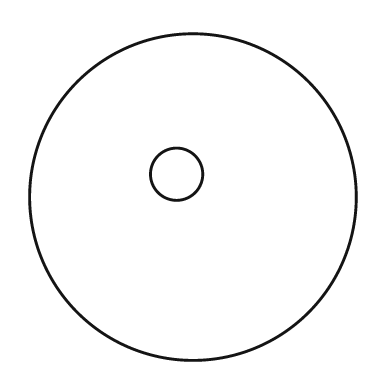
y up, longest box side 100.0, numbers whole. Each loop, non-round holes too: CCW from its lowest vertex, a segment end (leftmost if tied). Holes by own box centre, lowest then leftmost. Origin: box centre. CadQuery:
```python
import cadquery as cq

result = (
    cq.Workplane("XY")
    .moveTo(0.0, 0.0)
    .circle(50.0)
    .moveTo(-5.0, 7.0)
    .circle(8.0)
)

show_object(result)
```